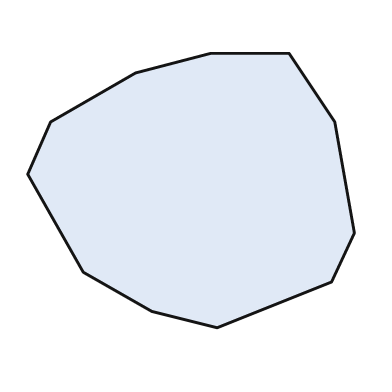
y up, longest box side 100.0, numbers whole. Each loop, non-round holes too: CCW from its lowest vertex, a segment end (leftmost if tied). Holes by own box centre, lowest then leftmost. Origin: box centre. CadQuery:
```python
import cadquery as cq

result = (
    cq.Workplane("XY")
    .moveTo(8.0, -42.0)
    .lineTo(43.0, -28.0)
    .lineTo(50.0, -13.0)
    .lineTo(44.0, 21.0)
    .lineTo(30.0, 42.0)
    .lineTo(6.0, 42.0)
    .lineTo(-17.0, 36.0)
    .lineTo(-43.0, 21.0)
    .lineTo(-50.0, 5.0)
    .lineTo(-33.0, -25.0)
    .lineTo(-12.0, -37.0)
    .close()
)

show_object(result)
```